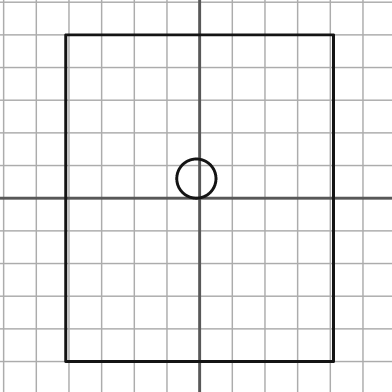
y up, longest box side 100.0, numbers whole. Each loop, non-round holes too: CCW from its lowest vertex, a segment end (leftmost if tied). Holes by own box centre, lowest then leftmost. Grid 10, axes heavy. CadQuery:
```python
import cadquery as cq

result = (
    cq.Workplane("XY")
    .moveTo(-41.0, -50.0)
    .lineTo(41.0, -50.0)
    .lineTo(41.0, 50.0)
    .lineTo(-41.0, 50.0)
    .close()
    .moveTo(-1.0, 6.0)
    .circle(6.0)
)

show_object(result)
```